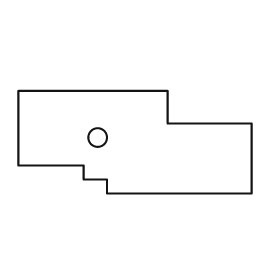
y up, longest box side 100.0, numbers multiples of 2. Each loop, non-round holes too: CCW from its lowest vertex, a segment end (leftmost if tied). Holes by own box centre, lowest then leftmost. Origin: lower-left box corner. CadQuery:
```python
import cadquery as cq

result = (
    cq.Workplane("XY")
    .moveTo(38.0, 0.0)
    .lineTo(100.0, 0.0)
    .lineTo(100.0, 30.0)
    .lineTo(64.0, 30.0)
    .lineTo(64.0, 44.0)
    .lineTo(0.0, 44.0)
    .lineTo(0.0, 12.0)
    .lineTo(28.0, 12.0)
    .lineTo(28.0, 6.0)
    .lineTo(38.0, 6.0)
    .close()
    .moveTo(34.0, 24.0)
    .circle(4.0)
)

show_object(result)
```